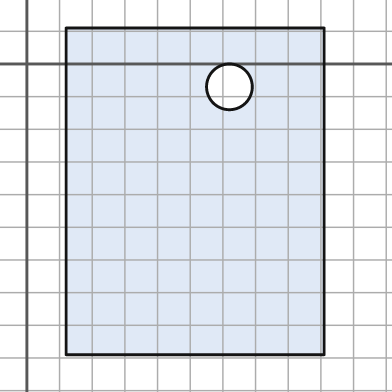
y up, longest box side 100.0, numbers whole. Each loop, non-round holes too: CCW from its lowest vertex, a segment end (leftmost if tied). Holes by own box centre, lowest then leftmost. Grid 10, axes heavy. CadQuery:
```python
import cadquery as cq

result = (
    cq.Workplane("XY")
    .moveTo(12.0, -89.0)
    .lineTo(91.0, -89.0)
    .lineTo(91.0, 11.0)
    .lineTo(12.0, 11.0)
    .close()
    .moveTo(62.0, -7.0)
    .circle(7.0)
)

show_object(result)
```